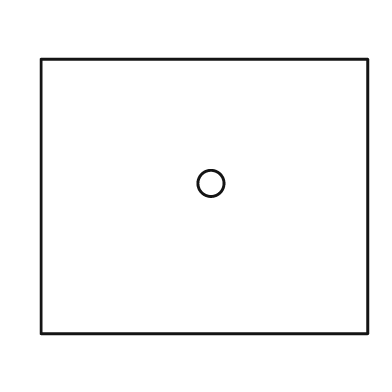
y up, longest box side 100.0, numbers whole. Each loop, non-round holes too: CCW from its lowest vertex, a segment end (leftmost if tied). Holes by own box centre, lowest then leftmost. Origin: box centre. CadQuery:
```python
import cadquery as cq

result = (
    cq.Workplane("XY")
    .moveTo(-50.0, -42.0)
    .lineTo(50.0, -42.0)
    .lineTo(50.0, 42.0)
    .lineTo(-50.0, 42.0)
    .close()
    .moveTo(2.0, 4.0)
    .circle(4.0)
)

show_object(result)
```